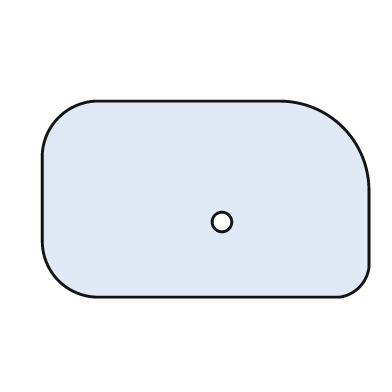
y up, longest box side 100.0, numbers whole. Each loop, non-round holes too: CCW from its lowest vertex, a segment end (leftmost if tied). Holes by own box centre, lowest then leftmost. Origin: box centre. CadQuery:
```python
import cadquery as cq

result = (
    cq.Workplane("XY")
    .moveTo(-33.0, -30.0)
    .lineTo(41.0, -30.0)
    .threePointArc((47.0, -27.0), (50.0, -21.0))
    .lineTo(50.0, 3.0)
    .threePointArc((42.0, 22.0), (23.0, 30.0))
    .lineTo(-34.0, 30.0)
    .threePointArc((-45.0, 25.0), (-50.0, 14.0))
    .lineTo(-50.0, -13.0)
    .threePointArc((-45.0, -25.0), (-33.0, -30.0))
    .close()
    .moveTo(5.0, -7.0)
    .circle(3.0)
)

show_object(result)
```